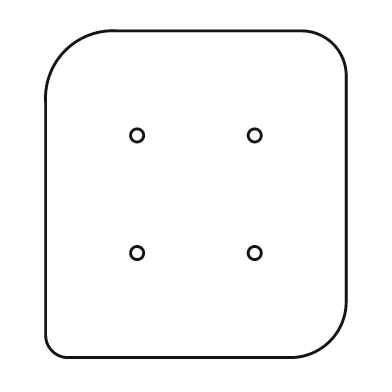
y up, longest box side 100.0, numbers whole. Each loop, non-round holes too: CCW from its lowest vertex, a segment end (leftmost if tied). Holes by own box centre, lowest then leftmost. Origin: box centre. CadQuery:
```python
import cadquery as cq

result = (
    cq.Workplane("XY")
    .moveTo(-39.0, -50.0)
    .lineTo(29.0, -50.0)
    .threePointArc((41.0, -45.0), (46.0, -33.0))
    .lineTo(46.0, 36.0)
    .threePointArc((42.0, 46.0), (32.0, 50.0))
    .lineTo(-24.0, 50.0)
    .threePointArc((-40.0, 44.0), (-46.0, 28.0))
    .lineTo(-46.0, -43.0)
    .threePointArc((-44.0, -48.0), (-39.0, -50.0))
    .close()
    .moveTo(-18.0, -18.0)
    .circle(2.0)
    .moveTo(18.0, -18.0)
    .circle(2.0)
    .moveTo(-18.0, 18.0)
    .circle(2.0)
    .moveTo(18.0, 18.0)
    .circle(2.0)
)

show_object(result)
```